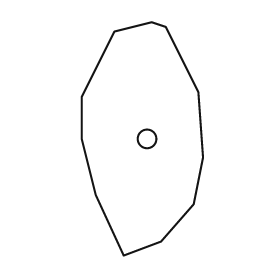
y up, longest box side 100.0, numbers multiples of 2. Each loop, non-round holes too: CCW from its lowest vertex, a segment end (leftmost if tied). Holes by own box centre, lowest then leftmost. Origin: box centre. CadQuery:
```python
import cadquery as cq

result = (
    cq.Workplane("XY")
    .moveTo(-8.0, -50.0)
    .lineTo(8.0, -44.0)
    .lineTo(22.0, -28.0)
    .lineTo(26.0, -8.0)
    .lineTo(24.0, 20.0)
    .lineTo(10.0, 48.0)
    .lineTo(4.0, 50.0)
    .lineTo(-12.0, 46.0)
    .lineTo(-26.0, 18.0)
    .lineTo(-26.0, 0.0)
    .lineTo(-20.0, -24.0)
    .close()
    .moveTo(2.0, 0.0)
    .circle(4.0)
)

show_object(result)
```